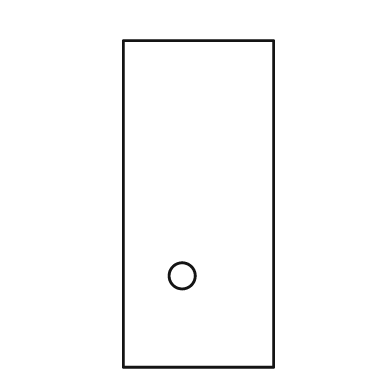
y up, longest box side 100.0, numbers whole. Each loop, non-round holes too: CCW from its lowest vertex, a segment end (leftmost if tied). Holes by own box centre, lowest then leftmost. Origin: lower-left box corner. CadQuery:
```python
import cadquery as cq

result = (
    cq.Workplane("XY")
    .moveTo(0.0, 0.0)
    .lineTo(46.0, 0.0)
    .lineTo(46.0, 100.0)
    .lineTo(0.0, 100.0)
    .close()
    .moveTo(18.0, 28.0)
    .circle(4.0)
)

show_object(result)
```